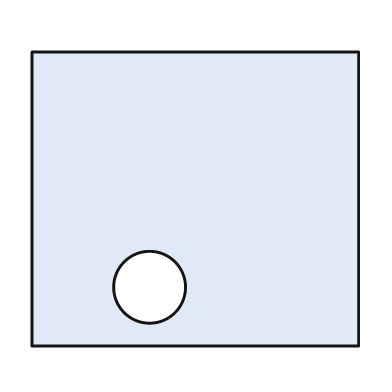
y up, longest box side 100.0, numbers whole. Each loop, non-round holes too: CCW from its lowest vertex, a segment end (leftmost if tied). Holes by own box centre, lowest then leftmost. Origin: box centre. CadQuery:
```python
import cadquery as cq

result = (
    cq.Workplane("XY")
    .moveTo(-50.0, -45.0)
    .lineTo(50.0, -45.0)
    .lineTo(50.0, 45.0)
    .lineTo(-50.0, 45.0)
    .close()
    .moveTo(-14.0, -27.0)
    .circle(11.0)
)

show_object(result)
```